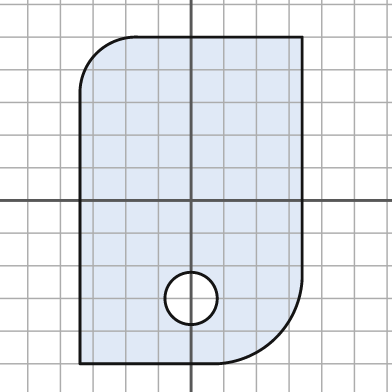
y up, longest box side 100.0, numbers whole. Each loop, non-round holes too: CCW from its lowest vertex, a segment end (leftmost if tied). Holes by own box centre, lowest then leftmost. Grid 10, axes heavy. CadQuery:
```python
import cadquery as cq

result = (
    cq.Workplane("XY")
    .moveTo(-34.0, -50.0)
    .lineTo(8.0, -50.0)
    .threePointArc((26.0, -42.0), (34.0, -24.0))
    .lineTo(34.0, 50.0)
    .lineTo(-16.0, 50.0)
    .threePointArc((-29.0, 45.0), (-34.0, 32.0))
    .close()
    .moveTo(0.0, -30.0)
    .circle(8.0)
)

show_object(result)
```